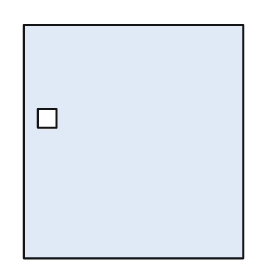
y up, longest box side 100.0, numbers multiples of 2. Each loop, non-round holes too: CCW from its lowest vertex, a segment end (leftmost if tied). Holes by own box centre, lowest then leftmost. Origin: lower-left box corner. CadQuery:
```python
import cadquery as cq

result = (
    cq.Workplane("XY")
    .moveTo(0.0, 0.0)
    .lineTo(94.0, 0.0)
    .lineTo(94.0, 100.0)
    .lineTo(0.0, 100.0)
    .close()
    .moveTo(6.0, 56.0)
    .lineTo(14.0, 56.0)
    .lineTo(14.0, 64.0)
    .lineTo(6.0, 64.0)
    .close()
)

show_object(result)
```